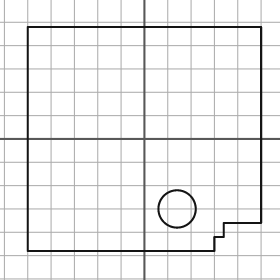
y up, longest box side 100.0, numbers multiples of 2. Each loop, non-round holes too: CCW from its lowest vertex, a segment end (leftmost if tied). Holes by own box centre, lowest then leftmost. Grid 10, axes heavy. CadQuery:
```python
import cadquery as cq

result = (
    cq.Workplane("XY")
    .moveTo(-50.0, -48.0)
    .lineTo(30.0, -48.0)
    .lineTo(30.0, -42.0)
    .lineTo(34.0, -42.0)
    .lineTo(34.0, -36.0)
    .lineTo(50.0, -36.0)
    .lineTo(50.0, 48.0)
    .lineTo(-50.0, 48.0)
    .close()
    .moveTo(14.0, -30.0)
    .circle(8.0)
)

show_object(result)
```